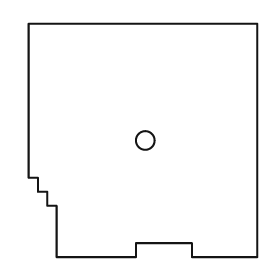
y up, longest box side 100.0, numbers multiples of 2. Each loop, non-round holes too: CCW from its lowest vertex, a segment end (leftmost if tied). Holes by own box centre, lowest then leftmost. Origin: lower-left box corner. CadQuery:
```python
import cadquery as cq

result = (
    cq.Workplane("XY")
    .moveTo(12.0, 0.0)
    .lineTo(46.0, 0.0)
    .lineTo(46.0, 6.0)
    .lineTo(70.0, 6.0)
    .lineTo(70.0, 0.0)
    .lineTo(98.0, 0.0)
    .lineTo(98.0, 100.0)
    .lineTo(0.0, 100.0)
    .lineTo(0.0, 34.0)
    .lineTo(4.0, 34.0)
    .lineTo(4.0, 28.0)
    .lineTo(8.0, 28.0)
    .lineTo(8.0, 22.0)
    .lineTo(12.0, 22.0)
    .close()
    .moveTo(50.0, 50.0)
    .circle(4.0)
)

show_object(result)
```